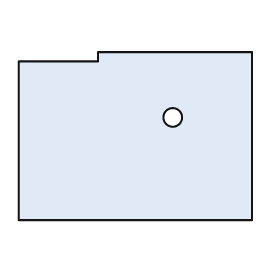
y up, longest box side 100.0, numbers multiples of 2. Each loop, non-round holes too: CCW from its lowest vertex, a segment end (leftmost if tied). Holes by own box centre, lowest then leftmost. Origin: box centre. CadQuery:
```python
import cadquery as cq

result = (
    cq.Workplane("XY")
    .moveTo(-50.0, -36.0)
    .lineTo(50.0, -36.0)
    .lineTo(50.0, 36.0)
    .lineTo(-16.0, 36.0)
    .lineTo(-16.0, 32.0)
    .lineTo(-50.0, 32.0)
    .close()
    .moveTo(16.0, 8.0)
    .circle(4.0)
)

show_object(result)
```